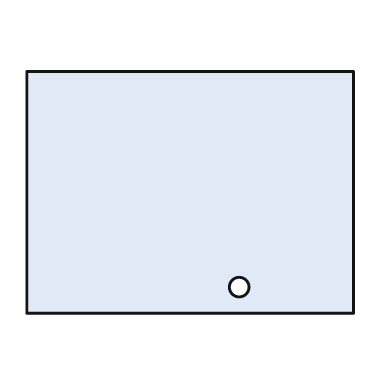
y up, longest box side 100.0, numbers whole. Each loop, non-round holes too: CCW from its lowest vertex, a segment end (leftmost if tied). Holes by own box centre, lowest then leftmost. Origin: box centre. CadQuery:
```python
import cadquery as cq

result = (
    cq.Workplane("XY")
    .moveTo(-50.0, -37.0)
    .lineTo(50.0, -37.0)
    .lineTo(50.0, 37.0)
    .lineTo(-50.0, 37.0)
    .close()
    .moveTo(15.0, -29.0)
    .circle(3.0)
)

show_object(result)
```